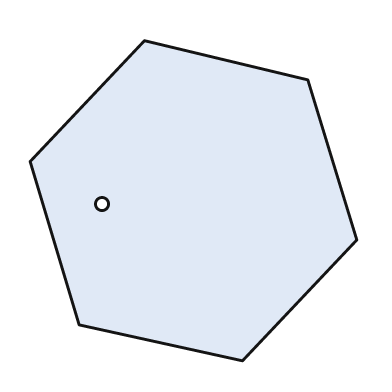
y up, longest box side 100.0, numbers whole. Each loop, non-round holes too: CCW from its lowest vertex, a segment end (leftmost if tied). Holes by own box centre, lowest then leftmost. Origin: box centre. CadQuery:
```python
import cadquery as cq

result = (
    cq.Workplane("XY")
    .moveTo(15.0, -49.0)
    .lineTo(50.0, -12.0)
    .lineTo(35.0, 37.0)
    .lineTo(-15.0, 49.0)
    .lineTo(-50.0, 12.0)
    .lineTo(-35.0, -38.0)
    .close()
    .moveTo(-28.0, -1.0)
    .circle(2.0)
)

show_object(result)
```